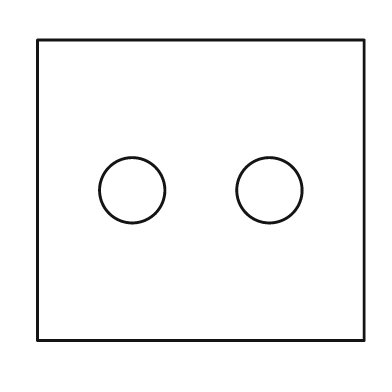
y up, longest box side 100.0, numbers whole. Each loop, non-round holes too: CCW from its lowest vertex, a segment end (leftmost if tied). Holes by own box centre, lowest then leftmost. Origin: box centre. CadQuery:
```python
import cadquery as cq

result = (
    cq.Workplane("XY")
    .moveTo(-50.0, -46.0)
    .lineTo(50.0, -46.0)
    .lineTo(50.0, 46.0)
    .lineTo(-50.0, 46.0)
    .close()
    .moveTo(-21.0, 0.0)
    .circle(10.0)
    .moveTo(21.0, 0.0)
    .circle(10.0)
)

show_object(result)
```